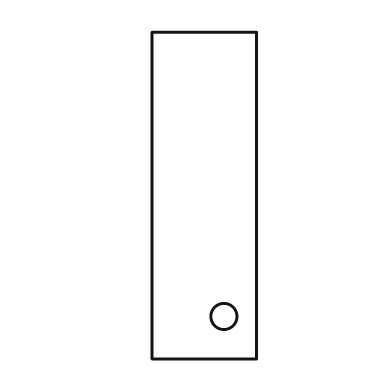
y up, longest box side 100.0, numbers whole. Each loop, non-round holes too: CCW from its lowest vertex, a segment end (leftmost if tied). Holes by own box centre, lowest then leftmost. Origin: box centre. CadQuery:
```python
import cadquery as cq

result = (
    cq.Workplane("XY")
    .moveTo(-16.0, -50.0)
    .lineTo(16.0, -50.0)
    .lineTo(16.0, 50.0)
    .lineTo(-16.0, 50.0)
    .close()
    .moveTo(6.0, -37.0)
    .circle(4.0)
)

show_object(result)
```